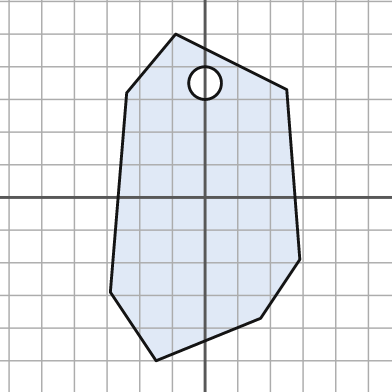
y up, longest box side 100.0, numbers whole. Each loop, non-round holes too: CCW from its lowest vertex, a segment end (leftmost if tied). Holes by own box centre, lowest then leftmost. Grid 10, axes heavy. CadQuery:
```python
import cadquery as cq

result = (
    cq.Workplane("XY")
    .moveTo(-15.0, -50.0)
    .lineTo(17.0, -37.0)
    .lineTo(29.0, -19.0)
    .lineTo(25.0, 33.0)
    .lineTo(-9.0, 50.0)
    .lineTo(-24.0, 32.0)
    .lineTo(-29.0, -29.0)
    .close()
    .moveTo(0.0, 35.0)
    .circle(5.0)
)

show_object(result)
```